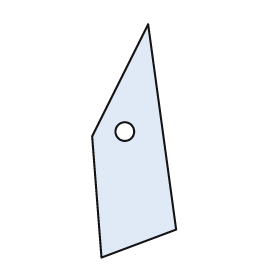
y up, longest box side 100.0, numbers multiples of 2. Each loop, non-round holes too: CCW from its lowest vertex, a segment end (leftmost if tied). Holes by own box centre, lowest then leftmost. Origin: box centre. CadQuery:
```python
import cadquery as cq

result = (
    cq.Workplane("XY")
    .moveTo(-14.0, -50.0)
    .lineTo(18.0, -38.0)
    .lineTo(6.0, 50.0)
    .lineTo(-18.0, 2.0)
    .close()
    .moveTo(-4.0, 4.0)
    .circle(4.0)
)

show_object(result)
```